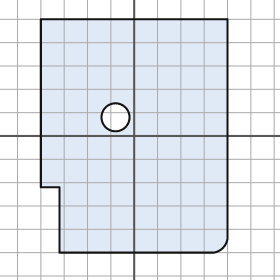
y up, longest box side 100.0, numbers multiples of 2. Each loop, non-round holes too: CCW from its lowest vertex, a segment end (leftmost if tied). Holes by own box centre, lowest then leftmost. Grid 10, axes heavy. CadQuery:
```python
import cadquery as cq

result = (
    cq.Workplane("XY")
    .moveTo(-32.0, -50.0)
    .lineTo(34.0, -50.0)
    .threePointArc((38.0, -48.0), (40.0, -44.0))
    .lineTo(40.0, 50.0)
    .lineTo(-40.0, 50.0)
    .lineTo(-40.0, -22.0)
    .lineTo(-32.0, -22.0)
    .close()
    .moveTo(-8.0, 8.0)
    .circle(6.0)
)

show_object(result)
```